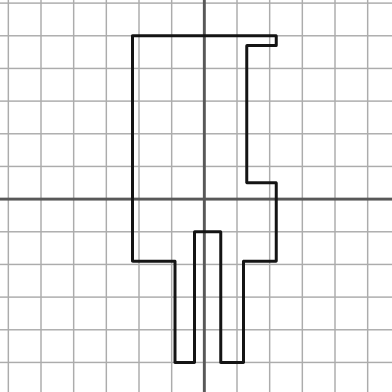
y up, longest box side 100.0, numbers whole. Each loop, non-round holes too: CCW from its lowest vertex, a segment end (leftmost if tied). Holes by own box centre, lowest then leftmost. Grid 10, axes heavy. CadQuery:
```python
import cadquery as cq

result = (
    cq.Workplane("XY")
    .moveTo(-9.0, -50.0)
    .lineTo(-3.0, -50.0)
    .lineTo(-3.0, -10.0)
    .lineTo(5.0, -10.0)
    .lineTo(5.0, -50.0)
    .lineTo(12.0, -50.0)
    .lineTo(12.0, -19.0)
    .lineTo(22.0, -19.0)
    .lineTo(22.0, 5.0)
    .lineTo(13.0, 5.0)
    .lineTo(13.0, 47.0)
    .lineTo(22.0, 47.0)
    .lineTo(22.0, 50.0)
    .lineTo(-22.0, 50.0)
    .lineTo(-22.0, -19.0)
    .lineTo(-9.0, -19.0)
    .close()
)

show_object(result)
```